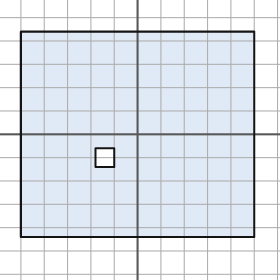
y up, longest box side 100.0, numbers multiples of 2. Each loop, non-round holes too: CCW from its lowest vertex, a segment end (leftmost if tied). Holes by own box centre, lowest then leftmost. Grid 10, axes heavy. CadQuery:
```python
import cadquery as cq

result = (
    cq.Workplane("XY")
    .moveTo(-50.0, -44.0)
    .lineTo(50.0, -44.0)
    .lineTo(50.0, 44.0)
    .lineTo(-50.0, 44.0)
    .close()
    .moveTo(-18.0, -14.0)
    .lineTo(-10.0, -14.0)
    .lineTo(-10.0, -6.0)
    .lineTo(-18.0, -6.0)
    .close()
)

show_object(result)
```